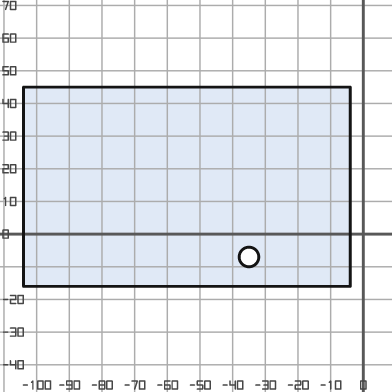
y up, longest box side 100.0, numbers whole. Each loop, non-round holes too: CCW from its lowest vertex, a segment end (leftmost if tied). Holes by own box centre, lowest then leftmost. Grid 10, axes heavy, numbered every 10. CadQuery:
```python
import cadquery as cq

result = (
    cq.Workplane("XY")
    .moveTo(-104.0, -16.0)
    .lineTo(-4.0, -16.0)
    .lineTo(-4.0, 45.0)
    .lineTo(-104.0, 45.0)
    .close()
    .moveTo(-35.0, -7.0)
    .circle(3.0)
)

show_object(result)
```